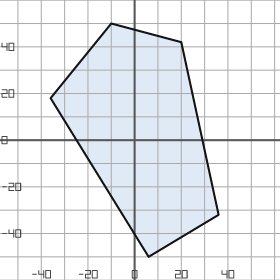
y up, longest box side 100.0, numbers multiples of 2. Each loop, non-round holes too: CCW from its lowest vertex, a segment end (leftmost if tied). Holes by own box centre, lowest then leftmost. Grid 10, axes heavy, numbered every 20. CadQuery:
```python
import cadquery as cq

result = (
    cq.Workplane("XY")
    .moveTo(6.0, -50.0)
    .lineTo(36.0, -32.0)
    .lineTo(20.0, 42.0)
    .lineTo(-10.0, 50.0)
    .lineTo(-36.0, 18.0)
    .close()
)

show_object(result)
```